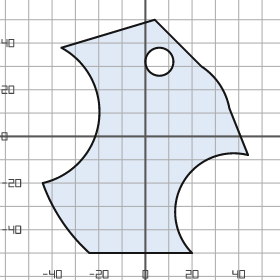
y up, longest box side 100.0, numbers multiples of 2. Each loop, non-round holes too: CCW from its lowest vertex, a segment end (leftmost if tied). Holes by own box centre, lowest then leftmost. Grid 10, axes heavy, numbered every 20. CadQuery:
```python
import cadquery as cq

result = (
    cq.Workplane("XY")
    .moveTo(-24.0, -50.0)
    .lineTo(20.0, -50.0)
    .threePointArc((16.0, -20.0), (44.0, -8.0))
    .lineTo(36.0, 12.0)
    .threePointArc((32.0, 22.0), (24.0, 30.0))
    .lineTo(4.0, 50.0)
    .lineTo(-36.0, 38.0)
    .threePointArc((-20.0, 6.0), (-44.0, -20.0))
    .threePointArc((-36.0, -36.0), (-24.0, -50.0))
    .close()
    .moveTo(6.0, 32.0)
    .circle(6.0)
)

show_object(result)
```